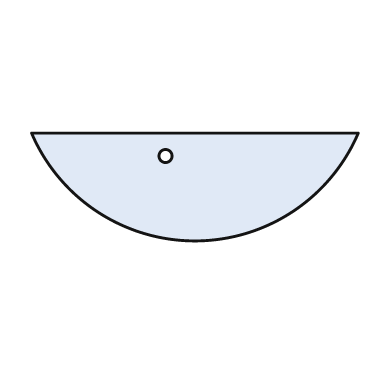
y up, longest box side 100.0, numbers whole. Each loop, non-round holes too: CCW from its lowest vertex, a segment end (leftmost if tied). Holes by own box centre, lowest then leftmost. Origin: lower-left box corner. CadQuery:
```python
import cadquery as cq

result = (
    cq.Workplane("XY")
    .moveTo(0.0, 33.0)
    .threePointArc((50.0, 0.0), (100.0, 33.0))
    .close()
    .moveTo(41.0, 26.0)
    .circle(2.0)
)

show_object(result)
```